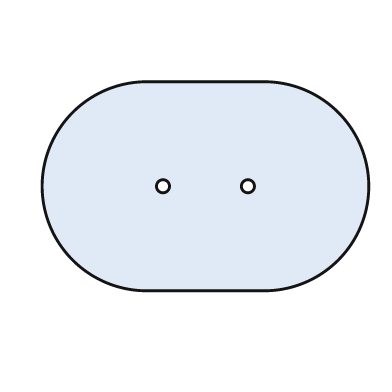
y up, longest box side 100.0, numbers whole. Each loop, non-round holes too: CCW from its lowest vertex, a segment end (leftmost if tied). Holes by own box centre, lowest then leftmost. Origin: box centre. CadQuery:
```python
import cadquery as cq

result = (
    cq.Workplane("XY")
    .moveTo(-18.0, -32.0)
    .lineTo(18.0, -32.0)
    .threePointArc((50.0, 0.0), (18.0, 32.0))
    .lineTo(-18.0, 32.0)
    .threePointArc((-50.0, 0.0), (-18.0, -32.0))
    .close()
    .moveTo(-13.0, 0.0)
    .circle(2.0)
    .moveTo(13.0, 0.0)
    .circle(2.0)
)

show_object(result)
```